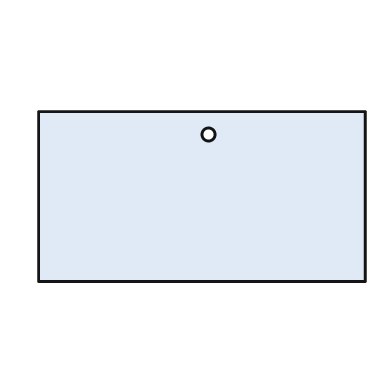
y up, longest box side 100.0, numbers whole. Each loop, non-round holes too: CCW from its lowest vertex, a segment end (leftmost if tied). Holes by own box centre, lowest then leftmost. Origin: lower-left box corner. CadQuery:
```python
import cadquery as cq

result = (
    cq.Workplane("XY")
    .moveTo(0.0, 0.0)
    .lineTo(100.0, 0.0)
    .lineTo(100.0, 52.0)
    .lineTo(0.0, 52.0)
    .close()
    .moveTo(52.0, 45.0)
    .circle(2.0)
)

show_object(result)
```